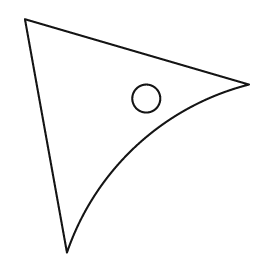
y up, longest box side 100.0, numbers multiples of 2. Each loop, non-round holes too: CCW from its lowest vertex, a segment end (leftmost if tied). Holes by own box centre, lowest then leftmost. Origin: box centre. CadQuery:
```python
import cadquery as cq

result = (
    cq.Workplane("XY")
    .moveTo(-30.0, -50.0)
    .threePointArc((0.0, -4.0), (48.0, 22.0))
    .lineTo(-48.0, 50.0)
    .close()
    .moveTo(4.0, 16.0)
    .circle(6.0)
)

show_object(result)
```